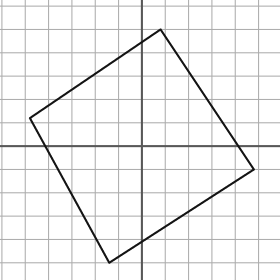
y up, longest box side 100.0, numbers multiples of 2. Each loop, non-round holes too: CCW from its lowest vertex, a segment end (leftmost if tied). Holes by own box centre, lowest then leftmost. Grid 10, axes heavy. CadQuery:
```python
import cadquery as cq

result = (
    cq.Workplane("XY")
    .moveTo(-14.0, -50.0)
    .lineTo(48.0, -10.0)
    .lineTo(8.0, 50.0)
    .lineTo(-48.0, 12.0)
    .close()
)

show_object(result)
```